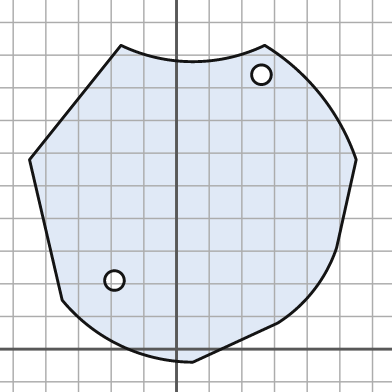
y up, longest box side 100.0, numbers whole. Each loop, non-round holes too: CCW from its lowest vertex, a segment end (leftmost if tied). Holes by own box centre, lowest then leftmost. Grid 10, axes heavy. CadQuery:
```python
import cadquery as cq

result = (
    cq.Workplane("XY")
    .moveTo(5.0, -4.0)
    .lineTo(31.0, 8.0)
    .threePointArc((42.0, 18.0), (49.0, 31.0))
    .lineTo(55.0, 58.0)
    .threePointArc((44.0, 78.0), (27.0, 93.0))
    .threePointArc((5.0, 88.0), (-17.0, 93.0))
    .lineTo(-45.0, 58.0)
    .lineTo(-35.0, 15.0)
    .threePointArc((-17.0, 1.0), (5.0, -4.0))
    .close()
    .moveTo(-19.0, 21.0)
    .circle(3.0)
    .moveTo(26.0, 84.0)
    .circle(3.0)
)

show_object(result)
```